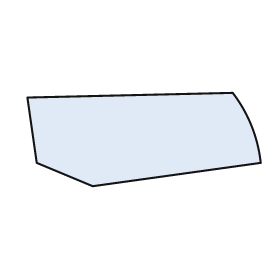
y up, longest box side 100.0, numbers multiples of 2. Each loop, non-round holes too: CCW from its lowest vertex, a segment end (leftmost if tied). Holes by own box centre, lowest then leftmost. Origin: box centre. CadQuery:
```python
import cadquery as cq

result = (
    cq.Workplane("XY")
    .moveTo(-22.0, -20.0)
    .lineTo(50.0, -10.0)
    .threePointArc((46.0, 6.0), (38.0, 20.0))
    .lineTo(-50.0, 18.0)
    .lineTo(-46.0, -10.0)
    .close()
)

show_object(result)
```